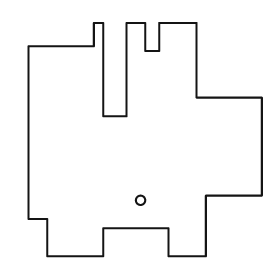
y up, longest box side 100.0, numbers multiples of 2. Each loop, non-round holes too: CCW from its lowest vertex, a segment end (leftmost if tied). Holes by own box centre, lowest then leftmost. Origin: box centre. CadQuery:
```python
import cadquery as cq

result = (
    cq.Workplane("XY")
    .moveTo(-42.0, -50.0)
    .lineTo(-18.0, -50.0)
    .lineTo(-18.0, -38.0)
    .lineTo(10.0, -38.0)
    .lineTo(10.0, -50.0)
    .lineTo(26.0, -50.0)
    .lineTo(26.0, -24.0)
    .lineTo(50.0, -24.0)
    .lineTo(50.0, 18.0)
    .lineTo(22.0, 18.0)
    .lineTo(22.0, 50.0)
    .lineTo(6.0, 50.0)
    .lineTo(6.0, 38.0)
    .lineTo(0.0, 38.0)
    .lineTo(0.0, 50.0)
    .lineTo(-8.0, 50.0)
    .lineTo(-8.0, 10.0)
    .lineTo(-18.0, 10.0)
    .lineTo(-18.0, 50.0)
    .lineTo(-22.0, 50.0)
    .lineTo(-22.0, 40.0)
    .lineTo(-50.0, 40.0)
    .lineTo(-50.0, -34.0)
    .lineTo(-42.0, -34.0)
    .close()
    .moveTo(-2.0, -26.0)
    .circle(2.0)
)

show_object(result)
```